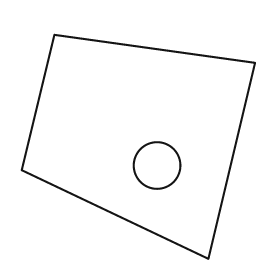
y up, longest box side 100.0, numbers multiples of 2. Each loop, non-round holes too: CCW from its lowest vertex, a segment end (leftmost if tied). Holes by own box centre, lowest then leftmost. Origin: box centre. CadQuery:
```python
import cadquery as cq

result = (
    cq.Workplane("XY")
    .moveTo(30.0, -48.0)
    .lineTo(50.0, 36.0)
    .lineTo(-36.0, 48.0)
    .lineTo(-50.0, -10.0)
    .close()
    .moveTo(8.0, -8.0)
    .circle(10.0)
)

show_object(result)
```